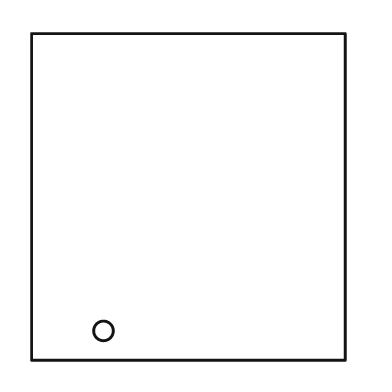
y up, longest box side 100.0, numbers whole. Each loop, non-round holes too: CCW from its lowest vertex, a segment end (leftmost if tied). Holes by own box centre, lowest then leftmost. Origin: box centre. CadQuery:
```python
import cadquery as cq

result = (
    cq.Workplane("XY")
    .moveTo(-48.0, -50.0)
    .lineTo(48.0, -50.0)
    .lineTo(48.0, 50.0)
    .lineTo(-48.0, 50.0)
    .close()
    .moveTo(-26.0, -41.0)
    .circle(3.0)
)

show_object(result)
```